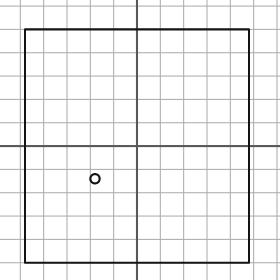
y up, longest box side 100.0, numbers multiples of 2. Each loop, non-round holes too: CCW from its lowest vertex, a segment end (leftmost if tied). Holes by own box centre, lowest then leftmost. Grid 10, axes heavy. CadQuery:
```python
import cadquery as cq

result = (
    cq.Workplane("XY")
    .moveTo(-48.0, -50.0)
    .lineTo(48.0, -50.0)
    .lineTo(48.0, 50.0)
    .lineTo(-48.0, 50.0)
    .close()
    .moveTo(-18.0, -14.0)
    .circle(2.0)
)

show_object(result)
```